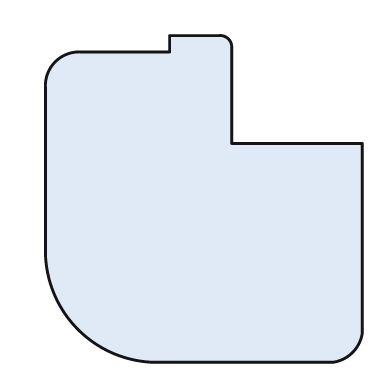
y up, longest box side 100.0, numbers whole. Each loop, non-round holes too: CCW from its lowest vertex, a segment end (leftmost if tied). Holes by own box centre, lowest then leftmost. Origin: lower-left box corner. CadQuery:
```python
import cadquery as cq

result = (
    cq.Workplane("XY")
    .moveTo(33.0, 0.0)
    .lineTo(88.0, 0.0)
    .threePointArc((94.0, 3.0), (97.0, 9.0))
    .lineTo(97.0, 67.0)
    .lineTo(57.0, 67.0)
    .lineTo(57.0, 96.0)
    .threePointArc((56.0, 99.0), (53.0, 100.0))
    .lineTo(38.0, 100.0)
    .lineTo(38.0, 95.0)
    .lineTo(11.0, 95.0)
    .threePointArc((3.0, 92.0), (0.0, 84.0))
    .lineTo(0.0, 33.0)
    .threePointArc((10.0, 10.0), (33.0, 0.0))
    .close()
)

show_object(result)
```